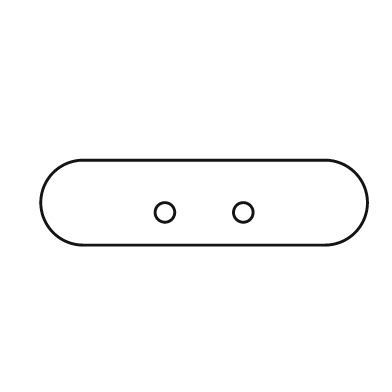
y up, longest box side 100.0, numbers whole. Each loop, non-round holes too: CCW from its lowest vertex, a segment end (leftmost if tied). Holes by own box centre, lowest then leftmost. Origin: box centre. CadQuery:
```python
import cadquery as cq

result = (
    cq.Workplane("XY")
    .moveTo(-37.0, -13.0)
    .lineTo(37.0, -13.0)
    .threePointArc((50.0, 0.0), (37.0, 13.0))
    .lineTo(-37.0, 13.0)
    .threePointArc((-50.0, 0.0), (-37.0, -13.0))
    .close()
    .moveTo(-12.0, -3.0)
    .circle(3.0)
    .moveTo(12.0, -3.0)
    .circle(3.0)
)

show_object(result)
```